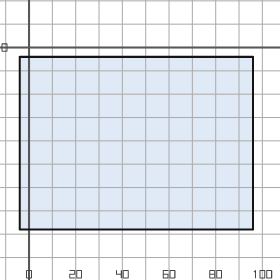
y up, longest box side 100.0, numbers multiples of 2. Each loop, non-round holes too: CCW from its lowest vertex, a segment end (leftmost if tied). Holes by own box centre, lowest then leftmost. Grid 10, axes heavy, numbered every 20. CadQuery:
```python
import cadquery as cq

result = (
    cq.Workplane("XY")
    .moveTo(-4.0, -78.0)
    .lineTo(96.0, -78.0)
    .lineTo(96.0, -4.0)
    .lineTo(-4.0, -4.0)
    .close()
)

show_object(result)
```